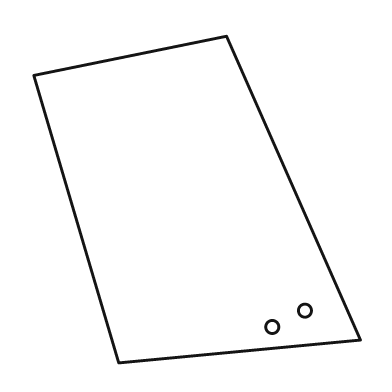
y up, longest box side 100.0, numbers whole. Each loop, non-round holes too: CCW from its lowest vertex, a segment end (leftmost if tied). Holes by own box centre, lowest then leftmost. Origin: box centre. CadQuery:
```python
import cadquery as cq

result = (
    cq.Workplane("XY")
    .moveTo(-24.0, -50.0)
    .lineTo(50.0, -43.0)
    .lineTo(9.0, 50.0)
    .lineTo(-50.0, 38.0)
    .close()
    .moveTo(23.0, -39.0)
    .circle(2.0)
    .moveTo(33.0, -34.0)
    .circle(2.0)
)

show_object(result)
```